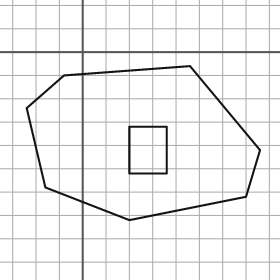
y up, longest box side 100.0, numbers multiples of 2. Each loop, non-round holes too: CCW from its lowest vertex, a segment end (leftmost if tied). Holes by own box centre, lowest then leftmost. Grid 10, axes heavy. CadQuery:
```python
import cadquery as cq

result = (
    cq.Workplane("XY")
    .moveTo(20.0, -72.0)
    .lineTo(70.0, -62.0)
    .lineTo(76.0, -42.0)
    .lineTo(46.0, -6.0)
    .lineTo(-8.0, -10.0)
    .lineTo(-24.0, -24.0)
    .lineTo(-16.0, -58.0)
    .close()
    .moveTo(20.0, -52.0)
    .lineTo(36.0, -52.0)
    .lineTo(36.0, -32.0)
    .lineTo(20.0, -32.0)
    .close()
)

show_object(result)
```